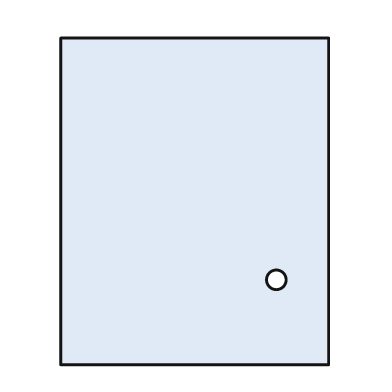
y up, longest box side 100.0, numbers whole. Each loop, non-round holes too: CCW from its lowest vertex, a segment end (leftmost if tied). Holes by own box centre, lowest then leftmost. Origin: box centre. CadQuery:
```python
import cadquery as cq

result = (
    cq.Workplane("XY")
    .moveTo(-41.0, -50.0)
    .lineTo(41.0, -50.0)
    .lineTo(41.0, 50.0)
    .lineTo(-41.0, 50.0)
    .close()
    .moveTo(25.0, -24.0)
    .circle(3.0)
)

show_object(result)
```